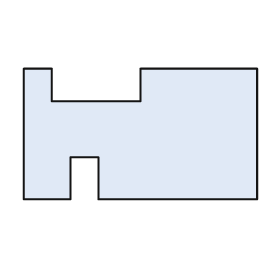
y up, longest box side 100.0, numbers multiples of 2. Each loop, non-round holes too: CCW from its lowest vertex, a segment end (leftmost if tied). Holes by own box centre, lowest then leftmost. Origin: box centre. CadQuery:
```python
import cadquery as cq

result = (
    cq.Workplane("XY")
    .moveTo(-50.0, -28.0)
    .lineTo(-30.0, -28.0)
    .lineTo(-30.0, -10.0)
    .lineTo(-18.0, -10.0)
    .lineTo(-18.0, -28.0)
    .lineTo(50.0, -28.0)
    .lineTo(50.0, 28.0)
    .lineTo(0.0, 28.0)
    .lineTo(0.0, 14.0)
    .lineTo(-38.0, 14.0)
    .lineTo(-38.0, 28.0)
    .lineTo(-50.0, 28.0)
    .close()
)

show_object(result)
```